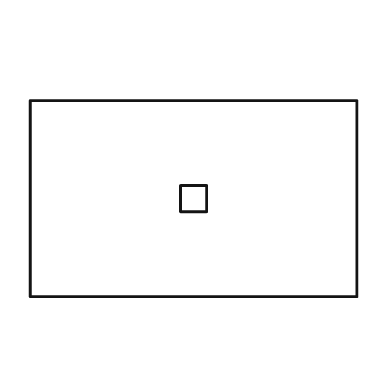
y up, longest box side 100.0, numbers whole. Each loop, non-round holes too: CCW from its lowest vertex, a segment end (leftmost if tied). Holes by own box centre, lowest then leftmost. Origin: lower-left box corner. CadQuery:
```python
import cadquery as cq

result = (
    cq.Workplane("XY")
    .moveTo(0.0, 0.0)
    .lineTo(100.0, 0.0)
    .lineTo(100.0, 60.0)
    .lineTo(0.0, 60.0)
    .close()
    .moveTo(46.0, 26.0)
    .lineTo(54.0, 26.0)
    .lineTo(54.0, 34.0)
    .lineTo(46.0, 34.0)
    .close()
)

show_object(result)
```